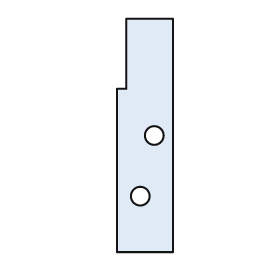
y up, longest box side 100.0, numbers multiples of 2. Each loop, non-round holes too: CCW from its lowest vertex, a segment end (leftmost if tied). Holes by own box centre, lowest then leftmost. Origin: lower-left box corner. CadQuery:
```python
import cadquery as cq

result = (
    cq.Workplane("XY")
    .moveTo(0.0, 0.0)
    .lineTo(24.0, 0.0)
    .lineTo(24.0, 100.0)
    .lineTo(4.0, 100.0)
    .lineTo(4.0, 70.0)
    .lineTo(0.0, 70.0)
    .close()
    .moveTo(10.0, 24.0)
    .circle(4.0)
    .moveTo(16.0, 50.0)
    .circle(4.0)
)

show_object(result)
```